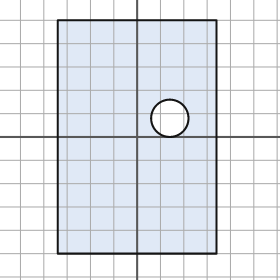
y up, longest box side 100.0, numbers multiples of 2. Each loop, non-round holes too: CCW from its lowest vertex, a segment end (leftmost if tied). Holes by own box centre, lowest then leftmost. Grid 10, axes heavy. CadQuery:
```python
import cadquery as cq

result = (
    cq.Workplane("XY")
    .moveTo(-34.0, -50.0)
    .lineTo(34.0, -50.0)
    .lineTo(34.0, 50.0)
    .lineTo(-34.0, 50.0)
    .close()
    .moveTo(14.0, 8.0)
    .circle(8.0)
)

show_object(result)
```